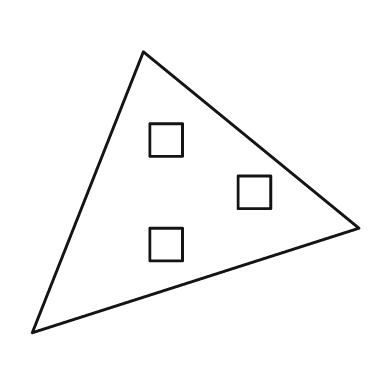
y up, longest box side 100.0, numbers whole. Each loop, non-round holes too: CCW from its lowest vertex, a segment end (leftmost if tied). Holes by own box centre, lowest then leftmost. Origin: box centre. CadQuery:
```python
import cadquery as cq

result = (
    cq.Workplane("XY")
    .moveTo(-50.0, -43.0)
    .lineTo(50.0, -11.0)
    .lineTo(-16.0, 43.0)
    .close()
    .moveTo(-14.0, -21.0)
    .lineTo(-4.0, -21.0)
    .lineTo(-4.0, -11.0)
    .lineTo(-14.0, -11.0)
    .close()
    .moveTo(13.0, -5.0)
    .lineTo(23.0, -5.0)
    .lineTo(23.0, 5.0)
    .lineTo(13.0, 5.0)
    .close()
    .moveTo(-14.0, 11.0)
    .lineTo(-4.0, 11.0)
    .lineTo(-4.0, 21.0)
    .lineTo(-14.0, 21.0)
    .close()
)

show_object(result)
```